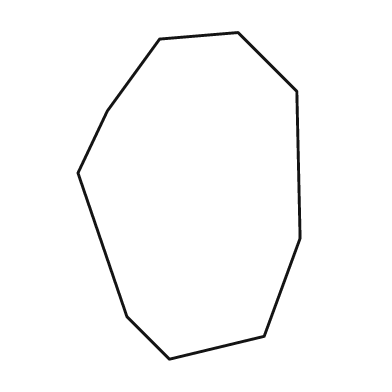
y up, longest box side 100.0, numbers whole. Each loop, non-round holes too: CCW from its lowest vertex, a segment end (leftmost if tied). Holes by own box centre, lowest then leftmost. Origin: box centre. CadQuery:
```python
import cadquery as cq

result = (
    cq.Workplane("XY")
    .moveTo(-6.0, -50.0)
    .lineTo(23.0, -43.0)
    .lineTo(34.0, -13.0)
    .lineTo(33.0, 32.0)
    .lineTo(15.0, 50.0)
    .lineTo(-9.0, 48.0)
    .lineTo(-25.0, 26.0)
    .lineTo(-34.0, 7.0)
    .lineTo(-19.0, -37.0)
    .close()
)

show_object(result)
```